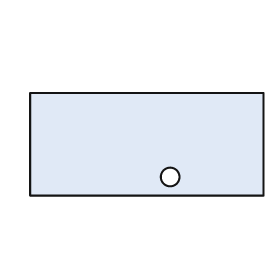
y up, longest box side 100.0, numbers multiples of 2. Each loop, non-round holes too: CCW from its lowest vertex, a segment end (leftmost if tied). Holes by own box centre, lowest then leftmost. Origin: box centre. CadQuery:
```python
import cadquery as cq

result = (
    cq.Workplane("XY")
    .moveTo(-50.0, -22.0)
    .lineTo(50.0, -22.0)
    .lineTo(50.0, 22.0)
    .lineTo(-50.0, 22.0)
    .close()
    .moveTo(10.0, -14.0)
    .circle(4.0)
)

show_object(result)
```